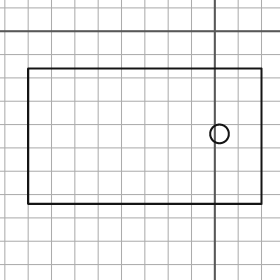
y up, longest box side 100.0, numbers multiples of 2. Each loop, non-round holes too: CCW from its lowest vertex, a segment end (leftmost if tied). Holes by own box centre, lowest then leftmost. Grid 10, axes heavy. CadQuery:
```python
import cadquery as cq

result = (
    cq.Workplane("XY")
    .moveTo(-80.0, -74.0)
    .lineTo(20.0, -74.0)
    .lineTo(20.0, -16.0)
    .lineTo(-80.0, -16.0)
    .close()
    .moveTo(2.0, -44.0)
    .circle(4.0)
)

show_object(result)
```